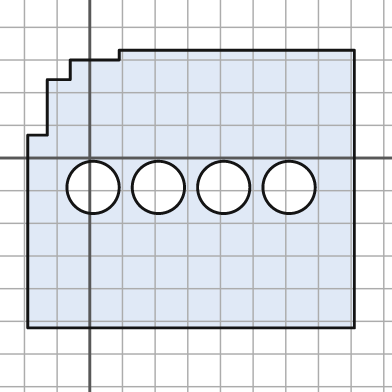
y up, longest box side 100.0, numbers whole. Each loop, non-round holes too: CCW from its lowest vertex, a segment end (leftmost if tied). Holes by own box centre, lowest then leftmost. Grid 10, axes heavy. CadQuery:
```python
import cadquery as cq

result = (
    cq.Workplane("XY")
    .moveTo(-19.0, -52.0)
    .lineTo(81.0, -52.0)
    .lineTo(81.0, 33.0)
    .lineTo(9.0, 33.0)
    .lineTo(9.0, 30.0)
    .lineTo(-6.0, 30.0)
    .lineTo(-6.0, 24.0)
    .lineTo(-13.0, 24.0)
    .lineTo(-13.0, 7.0)
    .lineTo(-19.0, 7.0)
    .close()
    .moveTo(1.0, -9.0)
    .circle(8.0)
    .moveTo(21.0, -9.0)
    .circle(8.0)
    .moveTo(41.0, -9.0)
    .circle(8.0)
    .moveTo(61.0, -9.0)
    .circle(8.0)
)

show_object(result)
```